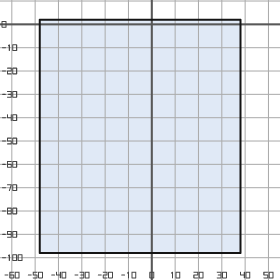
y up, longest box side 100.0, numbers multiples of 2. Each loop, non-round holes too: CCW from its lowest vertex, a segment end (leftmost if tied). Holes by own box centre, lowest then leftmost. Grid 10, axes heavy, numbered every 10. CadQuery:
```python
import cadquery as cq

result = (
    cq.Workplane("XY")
    .moveTo(-48.0, -98.0)
    .lineTo(38.0, -98.0)
    .lineTo(38.0, 2.0)
    .lineTo(-48.0, 2.0)
    .close()
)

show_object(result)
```